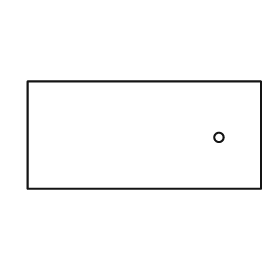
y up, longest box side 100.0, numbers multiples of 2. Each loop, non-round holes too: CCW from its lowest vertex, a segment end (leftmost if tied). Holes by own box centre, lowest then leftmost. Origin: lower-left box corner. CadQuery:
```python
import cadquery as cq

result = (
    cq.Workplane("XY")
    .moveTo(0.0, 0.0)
    .lineTo(100.0, 0.0)
    .lineTo(100.0, 46.0)
    .lineTo(0.0, 46.0)
    .close()
    .moveTo(82.0, 22.0)
    .circle(2.0)
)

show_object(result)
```